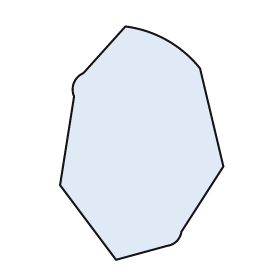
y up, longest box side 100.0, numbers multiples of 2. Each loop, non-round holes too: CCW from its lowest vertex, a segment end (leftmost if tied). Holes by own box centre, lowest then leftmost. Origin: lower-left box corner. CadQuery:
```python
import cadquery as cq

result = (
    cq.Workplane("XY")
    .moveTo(24.0, 0.0)
    .lineTo(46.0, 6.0)
    .threePointArc((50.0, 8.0), (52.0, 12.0))
    .lineTo(70.0, 40.0)
    .lineTo(60.0, 82.0)
    .threePointArc((46.0, 94.0), (28.0, 100.0))
    .lineTo(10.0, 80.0)
    .threePointArc((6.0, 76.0), (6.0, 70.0))
    .lineTo(0.0, 32.0)
    .close()
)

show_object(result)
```